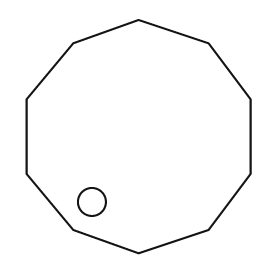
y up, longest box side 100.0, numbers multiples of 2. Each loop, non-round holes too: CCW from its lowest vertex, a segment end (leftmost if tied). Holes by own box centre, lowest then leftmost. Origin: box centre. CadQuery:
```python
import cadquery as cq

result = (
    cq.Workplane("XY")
    .moveTo(0.0, -50.0)
    .lineTo(30.0, -40.0)
    .lineTo(48.0, -16.0)
    .lineTo(48.0, 16.0)
    .lineTo(30.0, 40.0)
    .lineTo(0.0, 50.0)
    .lineTo(-28.0, 40.0)
    .lineTo(-48.0, 16.0)
    .lineTo(-48.0, -16.0)
    .lineTo(-28.0, -40.0)
    .close()
    .moveTo(-20.0, -28.0)
    .circle(6.0)
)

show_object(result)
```